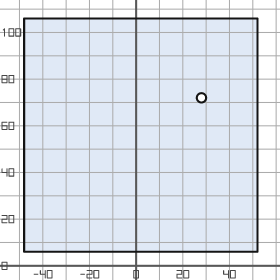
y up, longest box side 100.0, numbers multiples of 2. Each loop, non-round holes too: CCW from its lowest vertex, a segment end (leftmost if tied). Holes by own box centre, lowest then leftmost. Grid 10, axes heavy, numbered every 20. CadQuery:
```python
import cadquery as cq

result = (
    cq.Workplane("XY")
    .moveTo(-48.0, 6.0)
    .lineTo(52.0, 6.0)
    .lineTo(52.0, 106.0)
    .lineTo(-48.0, 106.0)
    .close()
    .moveTo(28.0, 72.0)
    .circle(2.0)
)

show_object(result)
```